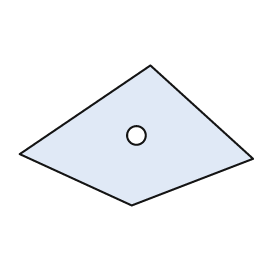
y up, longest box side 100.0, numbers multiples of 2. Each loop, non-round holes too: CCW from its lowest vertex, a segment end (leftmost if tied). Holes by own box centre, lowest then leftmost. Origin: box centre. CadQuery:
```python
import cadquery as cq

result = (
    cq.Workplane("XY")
    .moveTo(-2.0, -30.0)
    .lineTo(50.0, -10.0)
    .lineTo(6.0, 30.0)
    .lineTo(-50.0, -8.0)
    .close()
    .moveTo(0.0, 0.0)
    .circle(4.0)
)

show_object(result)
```